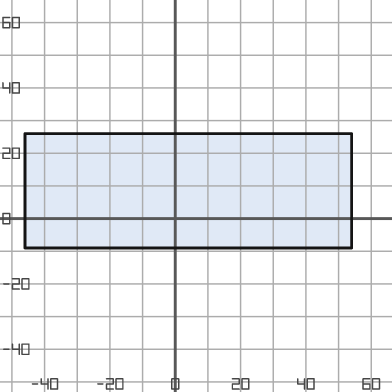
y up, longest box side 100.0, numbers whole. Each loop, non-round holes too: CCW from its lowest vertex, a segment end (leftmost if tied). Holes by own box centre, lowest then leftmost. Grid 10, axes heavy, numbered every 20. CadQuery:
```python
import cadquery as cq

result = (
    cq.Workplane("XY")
    .moveTo(-46.0, -9.0)
    .lineTo(54.0, -9.0)
    .lineTo(54.0, 26.0)
    .lineTo(-46.0, 26.0)
    .close()
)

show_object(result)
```